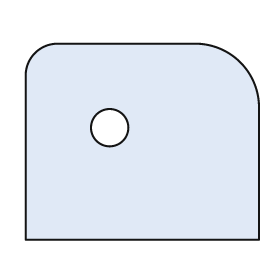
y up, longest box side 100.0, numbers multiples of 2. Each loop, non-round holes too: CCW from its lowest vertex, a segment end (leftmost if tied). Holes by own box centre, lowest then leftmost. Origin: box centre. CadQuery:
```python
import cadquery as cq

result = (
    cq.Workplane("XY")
    .moveTo(-50.0, -42.0)
    .lineTo(50.0, -42.0)
    .lineTo(50.0, 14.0)
    .threePointArc((42.0, 34.0), (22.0, 42.0))
    .lineTo(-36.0, 42.0)
    .threePointArc((-46.0, 38.0), (-50.0, 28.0))
    .close()
    .moveTo(-14.0, 6.0)
    .circle(8.0)
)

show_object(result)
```